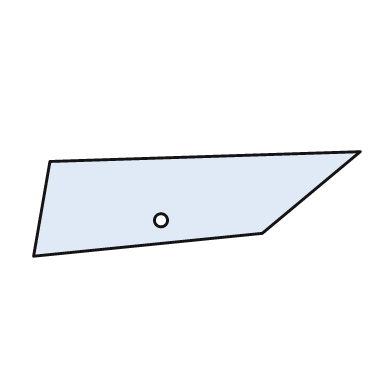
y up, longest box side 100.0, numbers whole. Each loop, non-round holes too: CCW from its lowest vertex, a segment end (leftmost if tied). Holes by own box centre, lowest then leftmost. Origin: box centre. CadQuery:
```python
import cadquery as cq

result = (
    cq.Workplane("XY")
    .moveTo(-50.0, -16.0)
    .lineTo(20.0, -9.0)
    .lineTo(50.0, 16.0)
    .lineTo(-45.0, 13.0)
    .close()
    .moveTo(-11.0, -5.0)
    .circle(2.0)
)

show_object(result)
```